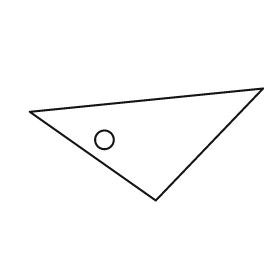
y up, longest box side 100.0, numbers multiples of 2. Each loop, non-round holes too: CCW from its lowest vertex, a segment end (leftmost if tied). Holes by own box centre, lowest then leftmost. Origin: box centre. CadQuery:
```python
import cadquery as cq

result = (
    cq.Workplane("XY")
    .moveTo(4.0, -24.0)
    .lineTo(50.0, 24.0)
    .lineTo(-50.0, 14.0)
    .close()
    .moveTo(-18.0, 2.0)
    .circle(4.0)
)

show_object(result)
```